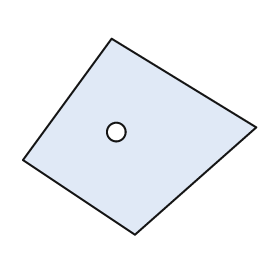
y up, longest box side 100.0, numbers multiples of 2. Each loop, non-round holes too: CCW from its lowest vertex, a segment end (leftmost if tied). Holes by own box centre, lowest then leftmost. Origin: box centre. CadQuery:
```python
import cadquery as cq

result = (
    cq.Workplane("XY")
    .moveTo(-2.0, -42.0)
    .lineTo(50.0, 4.0)
    .lineTo(-12.0, 42.0)
    .lineTo(-50.0, -10.0)
    .close()
    .moveTo(-10.0, 2.0)
    .circle(4.0)
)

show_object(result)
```